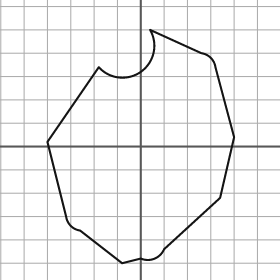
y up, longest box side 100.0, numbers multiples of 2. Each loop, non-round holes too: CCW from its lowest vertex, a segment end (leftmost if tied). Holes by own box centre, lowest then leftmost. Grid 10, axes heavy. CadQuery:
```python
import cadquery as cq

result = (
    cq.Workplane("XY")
    .moveTo(-8.0, -50.0)
    .lineTo(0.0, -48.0)
    .threePointArc((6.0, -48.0), (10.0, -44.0))
    .lineTo(34.0, -22.0)
    .lineTo(40.0, 4.0)
    .lineTo(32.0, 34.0)
    .threePointArc((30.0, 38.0), (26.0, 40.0))
    .lineTo(4.0, 50.0)
    .threePointArc((0.0, 32.0), (-18.0, 34.0))
    .lineTo(-40.0, 2.0)
    .lineTo(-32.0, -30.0)
    .threePointArc((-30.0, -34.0), (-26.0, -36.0))
    .close()
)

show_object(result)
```